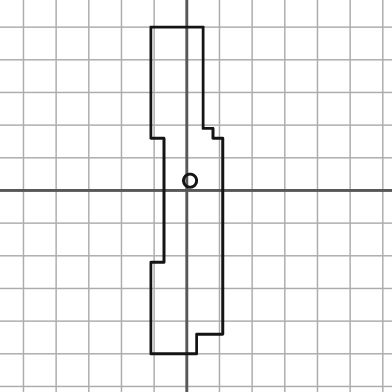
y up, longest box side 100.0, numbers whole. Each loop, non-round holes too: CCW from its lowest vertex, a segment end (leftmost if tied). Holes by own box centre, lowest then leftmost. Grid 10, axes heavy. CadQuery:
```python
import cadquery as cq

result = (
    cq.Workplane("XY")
    .moveTo(-11.0, -50.0)
    .lineTo(3.0, -50.0)
    .lineTo(3.0, -44.0)
    .lineTo(11.0, -44.0)
    .lineTo(11.0, 16.0)
    .lineTo(8.0, 16.0)
    .lineTo(8.0, 19.0)
    .lineTo(5.0, 19.0)
    .lineTo(5.0, 50.0)
    .lineTo(-11.0, 50.0)
    .lineTo(-11.0, 16.0)
    .lineTo(-7.0, 16.0)
    .lineTo(-7.0, -22.0)
    .lineTo(-11.0, -22.0)
    .close()
    .moveTo(1.0, 3.0)
    .circle(2.0)
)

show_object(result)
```